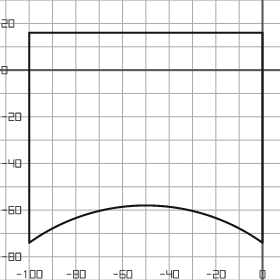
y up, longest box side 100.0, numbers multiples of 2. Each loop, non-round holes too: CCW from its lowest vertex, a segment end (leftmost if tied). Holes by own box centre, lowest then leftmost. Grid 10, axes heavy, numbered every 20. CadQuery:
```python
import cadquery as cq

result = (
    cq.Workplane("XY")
    .moveTo(-100.0, -74.0)
    .threePointArc((-50.0, -58.0), (0.0, -74.0))
    .lineTo(0.0, 16.0)
    .lineTo(-100.0, 16.0)
    .close()
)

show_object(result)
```